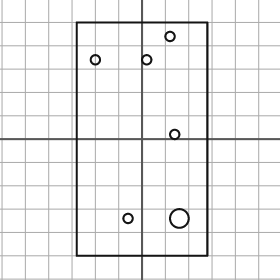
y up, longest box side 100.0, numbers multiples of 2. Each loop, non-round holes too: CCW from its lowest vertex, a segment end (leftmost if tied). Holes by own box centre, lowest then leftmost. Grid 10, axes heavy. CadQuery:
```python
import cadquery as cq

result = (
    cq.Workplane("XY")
    .moveTo(-28.0, -50.0)
    .lineTo(28.0, -50.0)
    .lineTo(28.0, 50.0)
    .lineTo(-28.0, 50.0)
    .close()
    .moveTo(-6.0, -34.0)
    .circle(2.0)
    .moveTo(16.0, -34.0)
    .circle(4.0)
    .moveTo(14.0, 2.0)
    .circle(2.0)
    .moveTo(-20.0, 34.0)
    .circle(2.0)
    .moveTo(2.0, 34.0)
    .circle(2.0)
    .moveTo(12.0, 44.0)
    .circle(2.0)
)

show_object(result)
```